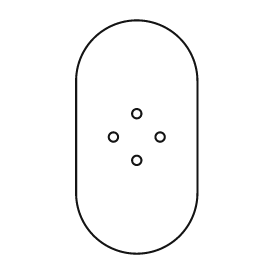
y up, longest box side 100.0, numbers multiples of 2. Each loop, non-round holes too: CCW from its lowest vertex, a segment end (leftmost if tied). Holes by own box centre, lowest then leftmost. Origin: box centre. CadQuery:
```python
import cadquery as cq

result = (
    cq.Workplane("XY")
    .moveTo(-26.0, -24.0)
    .threePointArc((0.0, -50.0), (26.0, -24.0))
    .lineTo(26.0, 24.0)
    .threePointArc((0.0, 50.0), (-26.0, 24.0))
    .close()
    .moveTo(0.0, -10.0)
    .circle(2.0)
    .moveTo(-10.0, 0.0)
    .circle(2.0)
    .moveTo(10.0, 0.0)
    .circle(2.0)
    .moveTo(0.0, 10.0)
    .circle(2.0)
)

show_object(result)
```